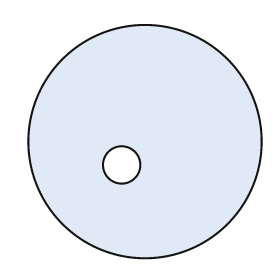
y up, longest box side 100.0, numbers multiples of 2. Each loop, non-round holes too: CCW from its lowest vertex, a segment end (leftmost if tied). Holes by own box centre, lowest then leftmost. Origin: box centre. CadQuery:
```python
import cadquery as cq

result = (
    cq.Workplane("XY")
    .moveTo(0.0, 0.0)
    .circle(50.0)
    .moveTo(-10.0, -10.0)
    .circle(8.0)
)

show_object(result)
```